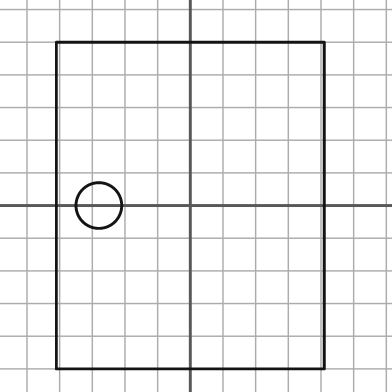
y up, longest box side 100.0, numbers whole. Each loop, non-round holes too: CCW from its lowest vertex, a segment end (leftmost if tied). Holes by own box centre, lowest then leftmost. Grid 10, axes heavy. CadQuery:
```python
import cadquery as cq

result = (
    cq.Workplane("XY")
    .moveTo(-41.0, -50.0)
    .lineTo(41.0, -50.0)
    .lineTo(41.0, 50.0)
    .lineTo(-41.0, 50.0)
    .close()
    .moveTo(-28.0, 0.0)
    .circle(7.0)
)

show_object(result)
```